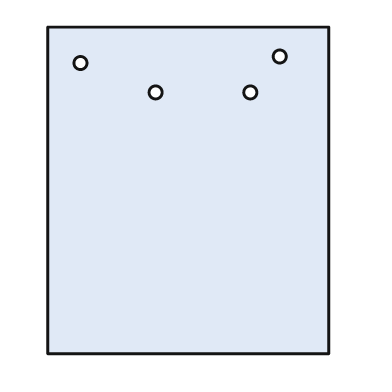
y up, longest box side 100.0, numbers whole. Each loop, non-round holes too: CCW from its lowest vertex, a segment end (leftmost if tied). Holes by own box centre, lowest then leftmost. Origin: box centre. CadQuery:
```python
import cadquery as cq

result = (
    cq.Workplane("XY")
    .moveTo(-43.0, -50.0)
    .lineTo(43.0, -50.0)
    .lineTo(43.0, 50.0)
    .lineTo(-43.0, 50.0)
    .close()
    .moveTo(-10.0, 30.0)
    .circle(2.0)
    .moveTo(19.0, 30.0)
    .circle(2.0)
    .moveTo(-33.0, 39.0)
    .circle(2.0)
    .moveTo(28.0, 41.0)
    .circle(2.0)
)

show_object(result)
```